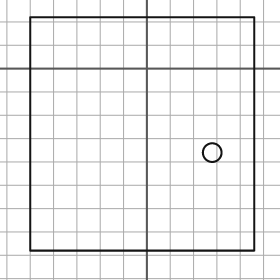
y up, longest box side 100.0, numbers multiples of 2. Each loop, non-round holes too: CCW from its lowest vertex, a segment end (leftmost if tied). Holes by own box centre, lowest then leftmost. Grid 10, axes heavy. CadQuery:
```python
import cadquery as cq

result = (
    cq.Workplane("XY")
    .moveTo(-50.0, -78.0)
    .lineTo(46.0, -78.0)
    .lineTo(46.0, 22.0)
    .lineTo(-50.0, 22.0)
    .close()
    .moveTo(28.0, -36.0)
    .circle(4.0)
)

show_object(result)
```